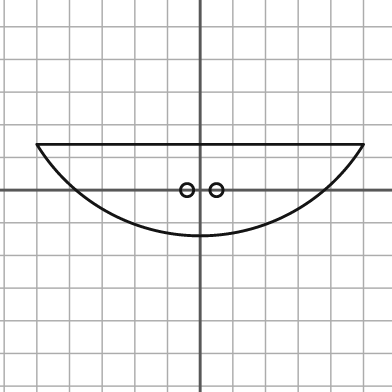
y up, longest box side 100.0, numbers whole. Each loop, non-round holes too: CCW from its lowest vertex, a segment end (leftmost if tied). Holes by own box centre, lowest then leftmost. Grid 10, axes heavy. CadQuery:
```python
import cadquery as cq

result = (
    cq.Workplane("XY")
    .moveTo(-50.0, 14.0)
    .threePointArc((0.0, -14.0), (50.0, 14.0))
    .close()
    .moveTo(-4.0, 0.0)
    .circle(2.0)
    .moveTo(5.0, 0.0)
    .circle(2.0)
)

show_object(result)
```